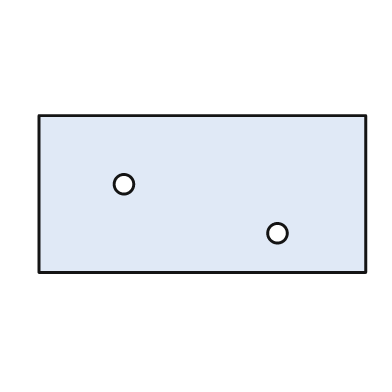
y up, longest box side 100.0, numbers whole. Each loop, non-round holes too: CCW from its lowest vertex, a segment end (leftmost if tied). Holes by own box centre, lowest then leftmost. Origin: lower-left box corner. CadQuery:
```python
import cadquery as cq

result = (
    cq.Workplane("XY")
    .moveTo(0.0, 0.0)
    .lineTo(100.0, 0.0)
    .lineTo(100.0, 48.0)
    .lineTo(0.0, 48.0)
    .close()
    .moveTo(73.0, 12.0)
    .circle(3.0)
    .moveTo(26.0, 27.0)
    .circle(3.0)
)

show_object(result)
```